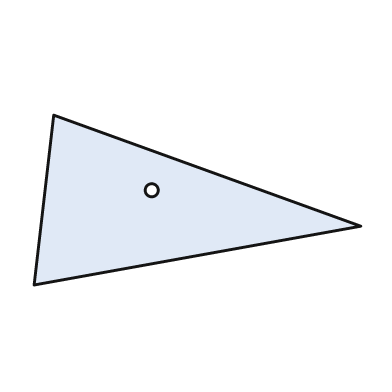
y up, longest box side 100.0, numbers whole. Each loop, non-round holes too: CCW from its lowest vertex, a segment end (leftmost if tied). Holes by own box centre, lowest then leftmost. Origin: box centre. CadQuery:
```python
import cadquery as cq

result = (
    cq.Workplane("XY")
    .moveTo(-50.0, -26.0)
    .lineTo(50.0, -8.0)
    .lineTo(-44.0, 26.0)
    .close()
    .moveTo(-14.0, 3.0)
    .circle(2.0)
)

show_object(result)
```